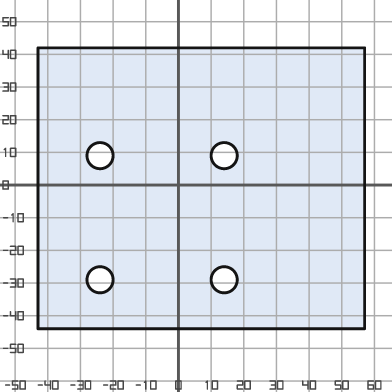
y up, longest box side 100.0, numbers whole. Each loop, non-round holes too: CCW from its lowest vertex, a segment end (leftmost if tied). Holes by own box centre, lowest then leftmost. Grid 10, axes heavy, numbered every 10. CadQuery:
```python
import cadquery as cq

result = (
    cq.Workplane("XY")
    .moveTo(-43.0, -44.0)
    .lineTo(57.0, -44.0)
    .lineTo(57.0, 42.0)
    .lineTo(-43.0, 42.0)
    .close()
    .moveTo(-24.0, -29.0)
    .circle(4.0)
    .moveTo(14.0, -29.0)
    .circle(4.0)
    .moveTo(-24.0, 9.0)
    .circle(4.0)
    .moveTo(14.0, 9.0)
    .circle(4.0)
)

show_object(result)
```